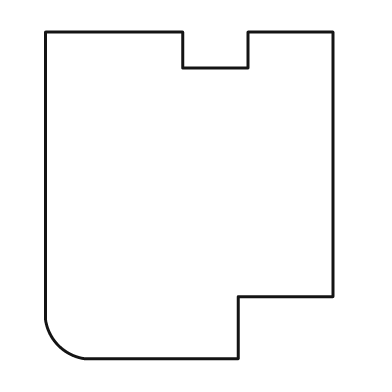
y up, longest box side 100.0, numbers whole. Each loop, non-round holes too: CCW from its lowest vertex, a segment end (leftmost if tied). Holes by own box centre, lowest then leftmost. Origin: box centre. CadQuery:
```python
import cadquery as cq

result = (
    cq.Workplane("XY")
    .moveTo(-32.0, -50.0)
    .lineTo(15.0, -50.0)
    .lineTo(15.0, -31.0)
    .lineTo(44.0, -31.0)
    .lineTo(44.0, 50.0)
    .lineTo(18.0, 50.0)
    .lineTo(18.0, 39.0)
    .lineTo(-2.0, 39.0)
    .lineTo(-2.0, 50.0)
    .lineTo(-44.0, 50.0)
    .lineTo(-44.0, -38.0)
    .threePointArc((-40.0, -46.0), (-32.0, -50.0))
    .close()
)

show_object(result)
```